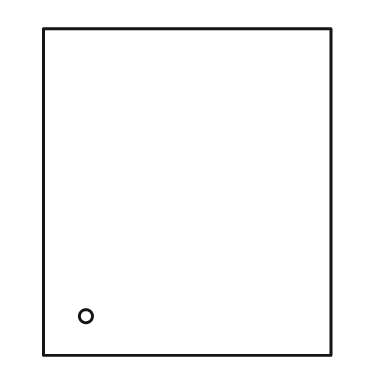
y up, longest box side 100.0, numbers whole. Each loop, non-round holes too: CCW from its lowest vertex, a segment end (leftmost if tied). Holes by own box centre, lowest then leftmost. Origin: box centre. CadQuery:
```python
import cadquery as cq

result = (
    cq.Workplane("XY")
    .moveTo(-44.0, -50.0)
    .lineTo(44.0, -50.0)
    .lineTo(44.0, 50.0)
    .lineTo(-44.0, 50.0)
    .close()
    .moveTo(-31.0, -38.0)
    .circle(2.0)
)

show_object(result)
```